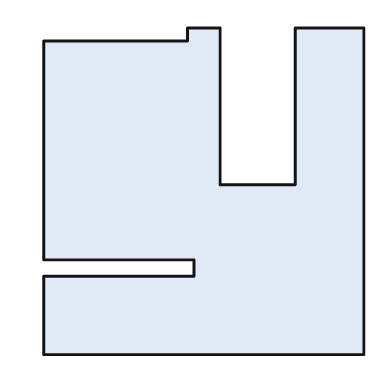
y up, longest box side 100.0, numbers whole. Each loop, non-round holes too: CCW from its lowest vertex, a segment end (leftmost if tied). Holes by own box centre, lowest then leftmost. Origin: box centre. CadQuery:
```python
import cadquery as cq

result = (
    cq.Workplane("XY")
    .moveTo(-49.0, -50.0)
    .lineTo(49.0, -50.0)
    .lineTo(49.0, 50.0)
    .lineTo(28.0, 50.0)
    .lineTo(28.0, 2.0)
    .lineTo(5.0, 2.0)
    .lineTo(5.0, 50.0)
    .lineTo(-5.0, 50.0)
    .lineTo(-5.0, 46.0)
    .lineTo(-49.0, 46.0)
    .lineTo(-49.0, -21.0)
    .lineTo(-3.0, -21.0)
    .lineTo(-3.0, -26.0)
    .lineTo(-49.0, -26.0)
    .close()
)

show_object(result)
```